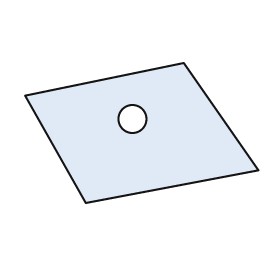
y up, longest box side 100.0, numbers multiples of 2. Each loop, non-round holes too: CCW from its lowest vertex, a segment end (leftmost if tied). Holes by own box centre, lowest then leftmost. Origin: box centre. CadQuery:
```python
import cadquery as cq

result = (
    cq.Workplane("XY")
    .moveTo(-24.0, -30.0)
    .lineTo(50.0, -16.0)
    .lineTo(18.0, 30.0)
    .lineTo(-50.0, 16.0)
    .close()
    .moveTo(-4.0, 6.0)
    .circle(6.0)
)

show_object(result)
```